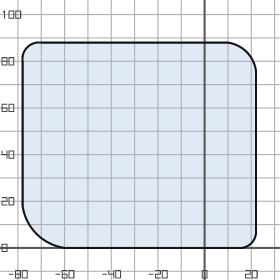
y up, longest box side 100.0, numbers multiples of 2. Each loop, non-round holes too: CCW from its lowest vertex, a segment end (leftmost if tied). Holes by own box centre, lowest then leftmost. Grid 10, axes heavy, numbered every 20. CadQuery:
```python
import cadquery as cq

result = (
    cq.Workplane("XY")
    .moveTo(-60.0, 0.0)
    .lineTo(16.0, 0.0)
    .threePointArc((20.0, 2.0), (22.0, 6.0))
    .lineTo(22.0, 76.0)
    .threePointArc((18.0, 84.0), (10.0, 88.0))
    .lineTo(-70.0, 88.0)
    .threePointArc((-76.0, 86.0), (-78.0, 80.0))
    .lineTo(-78.0, 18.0)
    .threePointArc((-72.0, 6.0), (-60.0, 0.0))
    .close()
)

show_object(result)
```